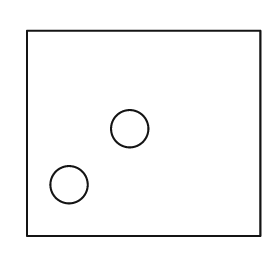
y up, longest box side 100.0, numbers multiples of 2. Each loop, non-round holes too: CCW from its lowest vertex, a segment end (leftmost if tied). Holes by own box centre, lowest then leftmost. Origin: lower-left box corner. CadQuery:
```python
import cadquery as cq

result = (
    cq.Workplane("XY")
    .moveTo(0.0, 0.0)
    .lineTo(100.0, 0.0)
    .lineTo(100.0, 88.0)
    .lineTo(0.0, 88.0)
    .close()
    .moveTo(18.0, 22.0)
    .circle(8.0)
    .moveTo(44.0, 46.0)
    .circle(8.0)
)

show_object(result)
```